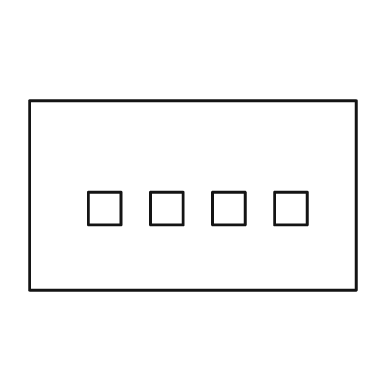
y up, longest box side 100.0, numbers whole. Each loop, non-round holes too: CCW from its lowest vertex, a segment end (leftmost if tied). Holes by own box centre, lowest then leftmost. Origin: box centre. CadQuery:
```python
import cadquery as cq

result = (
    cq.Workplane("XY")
    .moveTo(-50.0, -29.0)
    .lineTo(50.0, -29.0)
    .lineTo(50.0, 29.0)
    .lineTo(-50.0, 29.0)
    .close()
    .moveTo(-32.0, -9.0)
    .lineTo(-22.0, -9.0)
    .lineTo(-22.0, 1.0)
    .lineTo(-32.0, 1.0)
    .close()
    .moveTo(-13.0, -9.0)
    .lineTo(-3.0, -9.0)
    .lineTo(-3.0, 1.0)
    .lineTo(-13.0, 1.0)
    .close()
    .moveTo(6.0, -9.0)
    .lineTo(16.0, -9.0)
    .lineTo(16.0, 1.0)
    .lineTo(6.0, 1.0)
    .close()
    .moveTo(25.0, -9.0)
    .lineTo(35.0, -9.0)
    .lineTo(35.0, 1.0)
    .lineTo(25.0, 1.0)
    .close()
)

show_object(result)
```